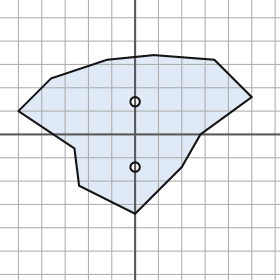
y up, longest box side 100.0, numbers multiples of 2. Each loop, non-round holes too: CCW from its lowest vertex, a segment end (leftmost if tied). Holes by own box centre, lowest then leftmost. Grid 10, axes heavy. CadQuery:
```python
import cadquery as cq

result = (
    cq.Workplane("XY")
    .moveTo(0.0, -34.0)
    .lineTo(20.0, -14.0)
    .lineTo(28.0, 0.0)
    .lineTo(50.0, 16.0)
    .lineTo(34.0, 32.0)
    .lineTo(8.0, 34.0)
    .lineTo(-12.0, 32.0)
    .lineTo(-36.0, 24.0)
    .lineTo(-50.0, 10.0)
    .lineTo(-26.0, -6.0)
    .lineTo(-24.0, -22.0)
    .close()
    .moveTo(0.0, -14.0)
    .circle(2.0)
    .moveTo(0.0, 14.0)
    .circle(2.0)
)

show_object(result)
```